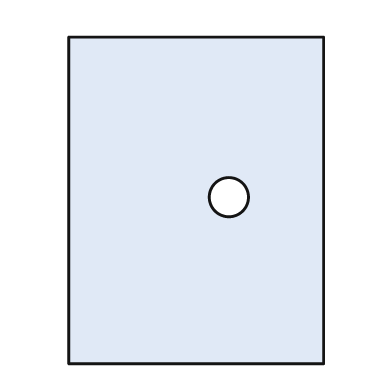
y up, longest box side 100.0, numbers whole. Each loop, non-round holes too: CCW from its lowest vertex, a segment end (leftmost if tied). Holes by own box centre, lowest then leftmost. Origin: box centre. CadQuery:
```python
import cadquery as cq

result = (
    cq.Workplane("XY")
    .moveTo(-39.0, -50.0)
    .lineTo(39.0, -50.0)
    .lineTo(39.0, 50.0)
    .lineTo(-39.0, 50.0)
    .close()
    .moveTo(10.0, 1.0)
    .circle(6.0)
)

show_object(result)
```